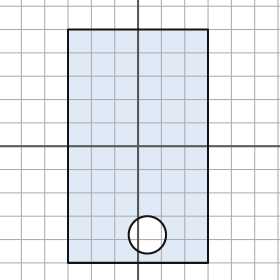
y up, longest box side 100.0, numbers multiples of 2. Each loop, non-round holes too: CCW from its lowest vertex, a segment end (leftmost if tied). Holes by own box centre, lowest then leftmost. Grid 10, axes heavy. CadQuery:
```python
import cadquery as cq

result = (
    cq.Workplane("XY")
    .moveTo(-30.0, -50.0)
    .lineTo(30.0, -50.0)
    .lineTo(30.0, 50.0)
    .lineTo(-30.0, 50.0)
    .close()
    .moveTo(4.0, -38.0)
    .circle(8.0)
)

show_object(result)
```